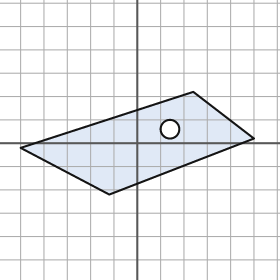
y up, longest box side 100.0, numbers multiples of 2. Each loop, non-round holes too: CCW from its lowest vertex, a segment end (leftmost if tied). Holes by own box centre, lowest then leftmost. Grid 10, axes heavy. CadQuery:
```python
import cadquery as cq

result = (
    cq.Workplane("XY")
    .moveTo(-12.0, -22.0)
    .lineTo(50.0, 2.0)
    .lineTo(24.0, 22.0)
    .lineTo(-50.0, -2.0)
    .close()
    .moveTo(14.0, 6.0)
    .circle(4.0)
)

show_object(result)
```